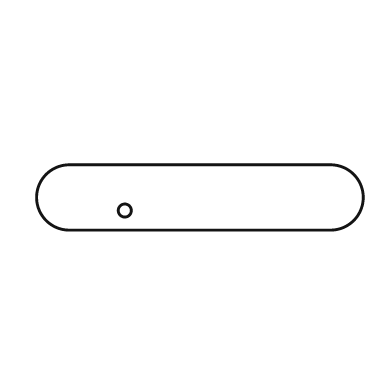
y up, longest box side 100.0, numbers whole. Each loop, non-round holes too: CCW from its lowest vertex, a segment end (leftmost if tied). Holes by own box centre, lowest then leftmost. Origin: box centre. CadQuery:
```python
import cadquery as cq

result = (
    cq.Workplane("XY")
    .moveTo(-40.0, -10.0)
    .lineTo(40.0, -10.0)
    .threePointArc((50.0, 0.0), (40.0, 10.0))
    .lineTo(-40.0, 10.0)
    .threePointArc((-50.0, 0.0), (-40.0, -10.0))
    .close()
    .moveTo(-23.0, -4.0)
    .circle(2.0)
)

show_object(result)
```